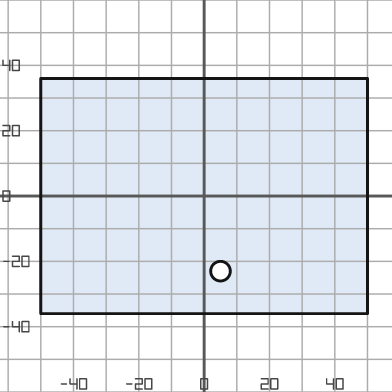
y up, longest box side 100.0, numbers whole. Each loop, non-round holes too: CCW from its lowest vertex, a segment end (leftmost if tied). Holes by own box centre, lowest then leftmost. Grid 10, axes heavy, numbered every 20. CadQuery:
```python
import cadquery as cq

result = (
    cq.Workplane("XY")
    .moveTo(-50.0, -36.0)
    .lineTo(50.0, -36.0)
    .lineTo(50.0, 36.0)
    .lineTo(-50.0, 36.0)
    .close()
    .moveTo(5.0, -23.0)
    .circle(3.0)
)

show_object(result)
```